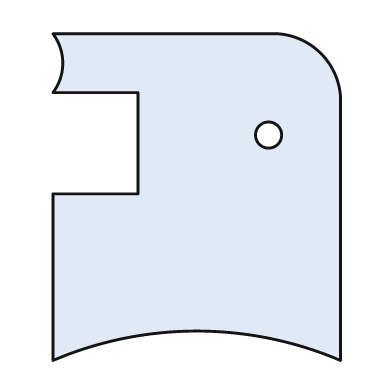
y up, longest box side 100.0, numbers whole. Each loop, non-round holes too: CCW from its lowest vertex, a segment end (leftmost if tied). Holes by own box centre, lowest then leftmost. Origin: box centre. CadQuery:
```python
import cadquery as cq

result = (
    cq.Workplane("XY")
    .moveTo(-44.0, -50.0)
    .threePointArc((0.0, -41.0), (44.0, -50.0))
    .lineTo(44.0, 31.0)
    .threePointArc((38.0, 44.0), (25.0, 50.0))
    .lineTo(-44.0, 50.0)
    .threePointArc((-41.0, 41.0), (-44.0, 32.0))
    .lineTo(-18.0, 32.0)
    .lineTo(-18.0, 1.0)
    .lineTo(-44.0, 1.0)
    .close()
    .moveTo(22.0, 19.0)
    .circle(4.0)
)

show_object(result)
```